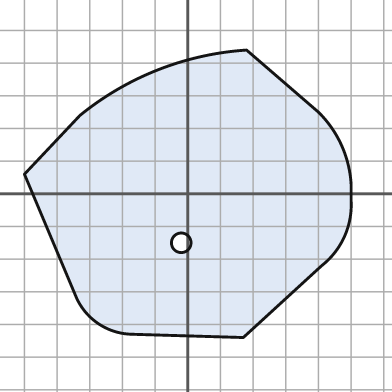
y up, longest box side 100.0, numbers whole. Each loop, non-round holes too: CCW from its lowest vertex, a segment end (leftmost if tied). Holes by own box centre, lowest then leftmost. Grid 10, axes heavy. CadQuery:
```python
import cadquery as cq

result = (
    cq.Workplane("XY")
    .moveTo(17.0, -44.0)
    .lineTo(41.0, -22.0)
    .threePointArc((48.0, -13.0), (50.0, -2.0))
    .lineTo(50.0, 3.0)
    .threePointArc((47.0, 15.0), (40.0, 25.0))
    .lineTo(18.0, 44.0)
    .threePointArc((-9.0, 38.0), (-33.0, 24.0))
    .lineTo(-50.0, 6.0)
    .lineTo(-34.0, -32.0)
    .threePointArc((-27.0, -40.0), (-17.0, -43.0))
    .close()
    .moveTo(-2.0, -15.0)
    .circle(3.0)
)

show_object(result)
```